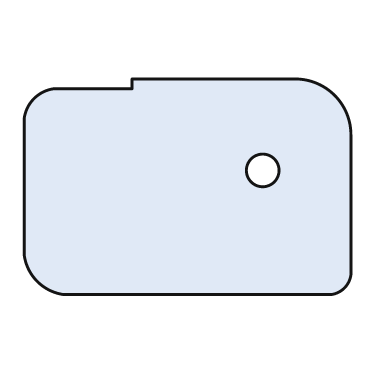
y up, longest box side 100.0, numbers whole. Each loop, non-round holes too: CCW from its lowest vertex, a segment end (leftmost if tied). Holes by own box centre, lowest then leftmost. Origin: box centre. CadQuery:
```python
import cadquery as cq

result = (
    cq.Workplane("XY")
    .moveTo(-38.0, -33.0)
    .lineTo(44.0, -33.0)
    .threePointArc((48.0, -31.0), (50.0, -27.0))
    .lineTo(50.0, 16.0)
    .threePointArc((45.0, 28.0), (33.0, 33.0))
    .lineTo(-17.0, 33.0)
    .lineTo(-17.0, 30.0)
    .lineTo(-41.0, 30.0)
    .threePointArc((-47.0, 27.0), (-50.0, 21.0))
    .lineTo(-50.0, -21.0)
    .threePointArc((-46.0, -29.0), (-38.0, -33.0))
    .close()
    .moveTo(23.0, 5.0)
    .circle(5.0)
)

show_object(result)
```